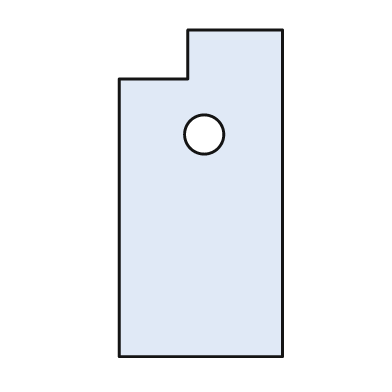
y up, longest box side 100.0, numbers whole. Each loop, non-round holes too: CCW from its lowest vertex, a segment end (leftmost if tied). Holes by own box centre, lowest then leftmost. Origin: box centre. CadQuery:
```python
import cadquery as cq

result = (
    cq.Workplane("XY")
    .moveTo(-25.0, -50.0)
    .lineTo(25.0, -50.0)
    .lineTo(25.0, 50.0)
    .lineTo(-4.0, 50.0)
    .lineTo(-4.0, 35.0)
    .lineTo(-25.0, 35.0)
    .close()
    .moveTo(1.0, 18.0)
    .circle(6.0)
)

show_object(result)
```